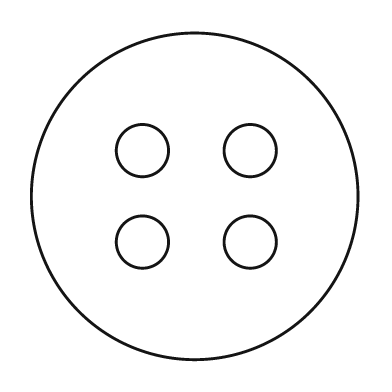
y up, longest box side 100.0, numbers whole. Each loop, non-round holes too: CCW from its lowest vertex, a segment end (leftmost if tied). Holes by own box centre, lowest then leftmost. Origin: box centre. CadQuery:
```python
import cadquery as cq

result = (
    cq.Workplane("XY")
    .moveTo(0.0, 0.0)
    .circle(50.0)
    .moveTo(-16.0, -14.0)
    .circle(8.0)
    .moveTo(17.0, -14.0)
    .circle(8.0)
    .moveTo(-16.0, 14.0)
    .circle(8.0)
    .moveTo(17.0, 14.0)
    .circle(8.0)
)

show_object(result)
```